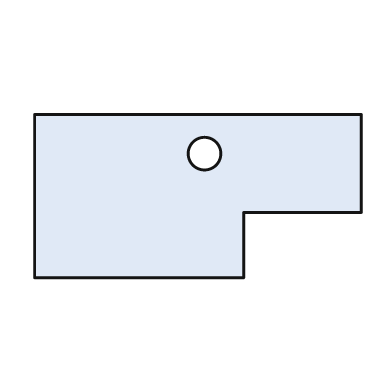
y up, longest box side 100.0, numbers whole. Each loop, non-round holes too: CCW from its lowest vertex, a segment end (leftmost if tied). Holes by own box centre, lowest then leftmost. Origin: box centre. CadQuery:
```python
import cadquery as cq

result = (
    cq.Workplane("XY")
    .moveTo(-50.0, -25.0)
    .lineTo(14.0, -25.0)
    .lineTo(14.0, -5.0)
    .lineTo(50.0, -5.0)
    .lineTo(50.0, 25.0)
    .lineTo(-50.0, 25.0)
    .close()
    .moveTo(2.0, 13.0)
    .circle(5.0)
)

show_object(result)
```